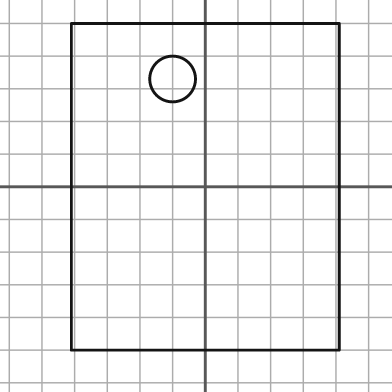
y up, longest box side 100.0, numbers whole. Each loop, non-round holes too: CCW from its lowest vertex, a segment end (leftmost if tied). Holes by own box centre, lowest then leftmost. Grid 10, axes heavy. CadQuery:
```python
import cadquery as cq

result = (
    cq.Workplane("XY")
    .moveTo(-41.0, -50.0)
    .lineTo(41.0, -50.0)
    .lineTo(41.0, 50.0)
    .lineTo(-41.0, 50.0)
    .close()
    .moveTo(-10.0, 33.0)
    .circle(7.0)
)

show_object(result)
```